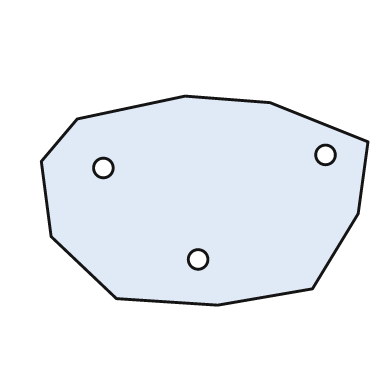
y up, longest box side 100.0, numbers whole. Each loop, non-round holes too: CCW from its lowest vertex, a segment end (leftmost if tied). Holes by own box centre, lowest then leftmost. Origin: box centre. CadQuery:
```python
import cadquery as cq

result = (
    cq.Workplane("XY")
    .moveTo(4.0, -32.0)
    .lineTo(33.0, -27.0)
    .lineTo(47.0, -4.0)
    .lineTo(50.0, 18.0)
    .lineTo(20.0, 30.0)
    .lineTo(-6.0, 32.0)
    .lineTo(-39.0, 25.0)
    .lineTo(-50.0, 12.0)
    .lineTo(-47.0, -11.0)
    .lineTo(-27.0, -30.0)
    .close()
    .moveTo(-2.0, -18.0)
    .circle(3.0)
    .moveTo(-31.0, 10.0)
    .circle(3.0)
    .moveTo(37.0, 14.0)
    .circle(3.0)
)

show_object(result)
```